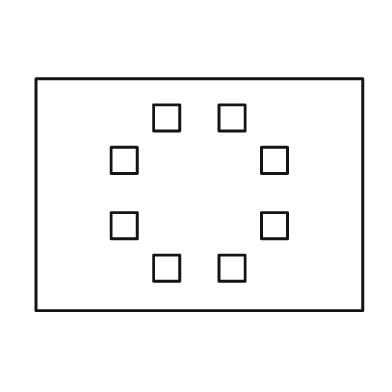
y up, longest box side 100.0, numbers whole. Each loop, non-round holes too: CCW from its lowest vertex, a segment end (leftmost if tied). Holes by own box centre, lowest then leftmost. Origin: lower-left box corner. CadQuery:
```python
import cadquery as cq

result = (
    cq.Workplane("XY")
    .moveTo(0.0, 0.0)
    .lineTo(100.0, 0.0)
    .lineTo(100.0, 71.0)
    .lineTo(0.0, 71.0)
    .close()
    .moveTo(36.0, 9.0)
    .lineTo(44.0, 9.0)
    .lineTo(44.0, 17.0)
    .lineTo(36.0, 17.0)
    .close()
    .moveTo(56.0, 9.0)
    .lineTo(64.0, 9.0)
    .lineTo(64.0, 17.0)
    .lineTo(56.0, 17.0)
    .close()
    .moveTo(23.0, 22.0)
    .lineTo(31.0, 22.0)
    .lineTo(31.0, 30.0)
    .lineTo(23.0, 30.0)
    .close()
    .moveTo(69.0, 22.0)
    .lineTo(77.0, 22.0)
    .lineTo(77.0, 30.0)
    .lineTo(69.0, 30.0)
    .close()
    .moveTo(23.0, 42.0)
    .lineTo(31.0, 42.0)
    .lineTo(31.0, 50.0)
    .lineTo(23.0, 50.0)
    .close()
    .moveTo(69.0, 42.0)
    .lineTo(77.0, 42.0)
    .lineTo(77.0, 50.0)
    .lineTo(69.0, 50.0)
    .close()
    .moveTo(36.0, 55.0)
    .lineTo(44.0, 55.0)
    .lineTo(44.0, 63.0)
    .lineTo(36.0, 63.0)
    .close()
    .moveTo(56.0, 55.0)
    .lineTo(64.0, 55.0)
    .lineTo(64.0, 63.0)
    .lineTo(56.0, 63.0)
    .close()
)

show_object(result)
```